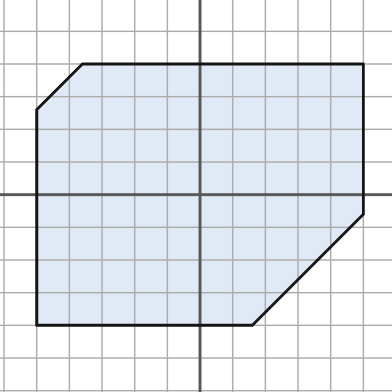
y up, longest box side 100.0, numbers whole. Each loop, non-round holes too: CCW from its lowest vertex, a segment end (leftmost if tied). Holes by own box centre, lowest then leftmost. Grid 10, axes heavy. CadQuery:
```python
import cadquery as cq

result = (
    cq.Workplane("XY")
    .moveTo(-50.0, -40.0)
    .lineTo(16.0, -40.0)
    .lineTo(50.0, -6.0)
    .lineTo(50.0, 40.0)
    .lineTo(-36.0, 40.0)
    .lineTo(-50.0, 26.0)
    .close()
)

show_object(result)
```